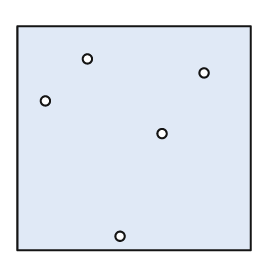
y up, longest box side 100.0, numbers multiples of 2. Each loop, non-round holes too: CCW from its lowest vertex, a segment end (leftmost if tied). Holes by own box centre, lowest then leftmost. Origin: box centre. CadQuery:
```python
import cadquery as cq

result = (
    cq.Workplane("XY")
    .moveTo(-50.0, -48.0)
    .lineTo(50.0, -48.0)
    .lineTo(50.0, 48.0)
    .lineTo(-50.0, 48.0)
    .close()
    .moveTo(-6.0, -42.0)
    .circle(2.0)
    .moveTo(12.0, 2.0)
    .circle(2.0)
    .moveTo(-38.0, 16.0)
    .circle(2.0)
    .moveTo(30.0, 28.0)
    .circle(2.0)
    .moveTo(-20.0, 34.0)
    .circle(2.0)
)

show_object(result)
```